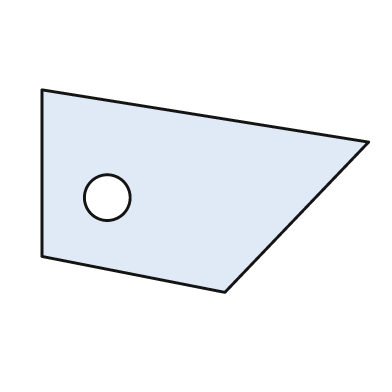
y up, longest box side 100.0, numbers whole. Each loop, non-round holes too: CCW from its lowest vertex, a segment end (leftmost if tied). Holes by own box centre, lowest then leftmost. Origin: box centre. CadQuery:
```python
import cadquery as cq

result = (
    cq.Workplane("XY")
    .moveTo(6.0, -31.0)
    .lineTo(50.0, 15.0)
    .lineTo(-50.0, 31.0)
    .lineTo(-50.0, -20.0)
    .close()
    .moveTo(-30.0, -2.0)
    .circle(7.0)
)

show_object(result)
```